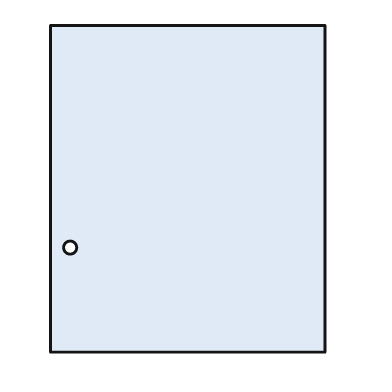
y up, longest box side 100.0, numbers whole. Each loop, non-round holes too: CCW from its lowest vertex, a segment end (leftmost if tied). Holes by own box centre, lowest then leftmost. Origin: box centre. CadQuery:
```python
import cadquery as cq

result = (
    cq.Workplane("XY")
    .moveTo(-42.0, -50.0)
    .lineTo(42.0, -50.0)
    .lineTo(42.0, 50.0)
    .lineTo(-42.0, 50.0)
    .close()
    .moveTo(-36.0, -18.0)
    .circle(2.0)
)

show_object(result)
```